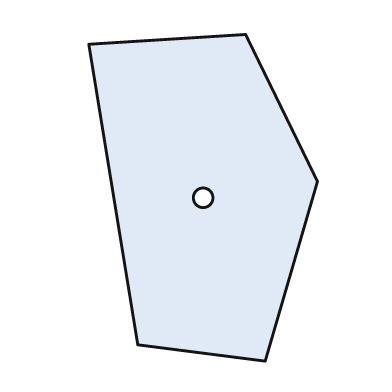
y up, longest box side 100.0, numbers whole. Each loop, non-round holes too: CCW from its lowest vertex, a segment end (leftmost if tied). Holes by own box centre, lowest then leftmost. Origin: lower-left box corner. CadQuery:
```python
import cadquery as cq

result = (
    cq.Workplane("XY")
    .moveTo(54.0, 0.0)
    .lineTo(70.0, 55.0)
    .lineTo(48.0, 100.0)
    .lineTo(0.0, 97.0)
    .lineTo(15.0, 5.0)
    .close()
    .moveTo(35.0, 50.0)
    .circle(3.0)
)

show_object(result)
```